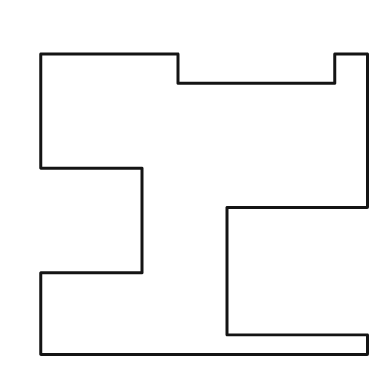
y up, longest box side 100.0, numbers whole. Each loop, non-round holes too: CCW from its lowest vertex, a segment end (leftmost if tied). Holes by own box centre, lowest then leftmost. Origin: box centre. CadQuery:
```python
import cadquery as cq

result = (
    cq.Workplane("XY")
    .moveTo(-50.0, -46.0)
    .lineTo(50.0, -46.0)
    .lineTo(50.0, -40.0)
    .lineTo(7.0, -40.0)
    .lineTo(7.0, -1.0)
    .lineTo(50.0, -1.0)
    .lineTo(50.0, 46.0)
    .lineTo(40.0, 46.0)
    .lineTo(40.0, 37.0)
    .lineTo(-8.0, 37.0)
    .lineTo(-8.0, 46.0)
    .lineTo(-50.0, 46.0)
    .lineTo(-50.0, 11.0)
    .lineTo(-19.0, 11.0)
    .lineTo(-19.0, -21.0)
    .lineTo(-50.0, -21.0)
    .close()
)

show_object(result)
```